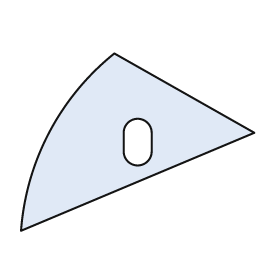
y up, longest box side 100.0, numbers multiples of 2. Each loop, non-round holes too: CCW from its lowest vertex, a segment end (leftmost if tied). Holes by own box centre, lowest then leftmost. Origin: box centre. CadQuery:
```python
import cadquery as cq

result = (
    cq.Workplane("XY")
    .moveTo(-50.0, -38.0)
    .lineTo(50.0, 4.0)
    .lineTo(-10.0, 38.0)
    .threePointArc((-38.0, 4.0), (-50.0, -38.0))
    .close()
    .moveTo(-6.0, -4.0)
    .threePointArc((0.0, -10.0), (6.0, -4.0))
    .lineTo(6.0, 4.0)
    .threePointArc((0.0, 10.0), (-6.0, 4.0))
    .close()
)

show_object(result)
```